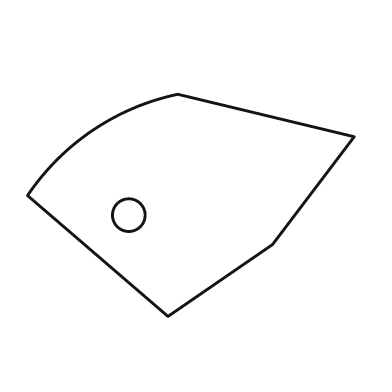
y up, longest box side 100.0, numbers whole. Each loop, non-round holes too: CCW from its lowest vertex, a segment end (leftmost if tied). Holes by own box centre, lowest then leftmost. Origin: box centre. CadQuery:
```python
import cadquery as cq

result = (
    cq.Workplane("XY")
    .moveTo(-7.0, -34.0)
    .lineTo(25.0, -12.0)
    .lineTo(50.0, 21.0)
    .lineTo(-4.0, 34.0)
    .threePointArc((-30.0, 23.0), (-50.0, 3.0))
    .close()
    .moveTo(-19.0, -3.0)
    .circle(5.0)
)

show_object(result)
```